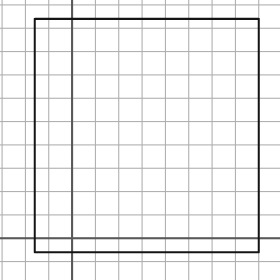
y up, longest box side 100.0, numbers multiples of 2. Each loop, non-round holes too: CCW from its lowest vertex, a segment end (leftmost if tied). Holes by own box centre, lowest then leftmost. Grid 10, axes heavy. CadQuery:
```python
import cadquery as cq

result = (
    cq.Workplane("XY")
    .moveTo(-16.0, -6.0)
    .lineTo(80.0, -6.0)
    .lineTo(80.0, 94.0)
    .lineTo(-16.0, 94.0)
    .close()
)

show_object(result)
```